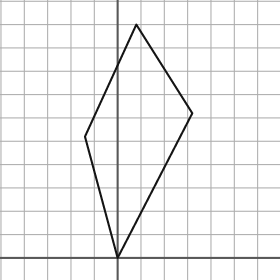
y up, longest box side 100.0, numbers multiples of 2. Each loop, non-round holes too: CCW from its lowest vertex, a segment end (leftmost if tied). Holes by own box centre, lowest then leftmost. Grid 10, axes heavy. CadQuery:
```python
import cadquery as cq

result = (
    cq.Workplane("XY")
    .moveTo(0.0, 0.0)
    .lineTo(32.0, 62.0)
    .lineTo(8.0, 100.0)
    .lineTo(-14.0, 52.0)
    .close()
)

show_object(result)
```